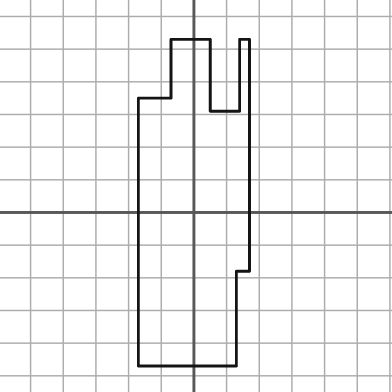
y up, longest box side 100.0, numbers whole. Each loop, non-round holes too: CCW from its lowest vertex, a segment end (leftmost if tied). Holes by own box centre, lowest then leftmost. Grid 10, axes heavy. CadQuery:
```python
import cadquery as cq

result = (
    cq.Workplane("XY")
    .moveTo(-17.0, -47.0)
    .lineTo(13.0, -47.0)
    .lineTo(13.0, -18.0)
    .lineTo(17.0, -18.0)
    .lineTo(17.0, 53.0)
    .lineTo(14.0, 53.0)
    .lineTo(14.0, 31.0)
    .lineTo(5.0, 31.0)
    .lineTo(5.0, 53.0)
    .lineTo(-7.0, 53.0)
    .lineTo(-7.0, 35.0)
    .lineTo(-17.0, 35.0)
    .close()
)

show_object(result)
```